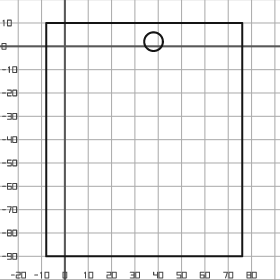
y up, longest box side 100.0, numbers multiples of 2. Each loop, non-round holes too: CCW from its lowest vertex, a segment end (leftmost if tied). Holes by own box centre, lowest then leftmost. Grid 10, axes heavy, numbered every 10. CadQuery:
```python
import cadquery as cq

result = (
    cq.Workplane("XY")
    .moveTo(-8.0, -90.0)
    .lineTo(76.0, -90.0)
    .lineTo(76.0, 10.0)
    .lineTo(-8.0, 10.0)
    .close()
    .moveTo(38.0, 2.0)
    .circle(4.0)
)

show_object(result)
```